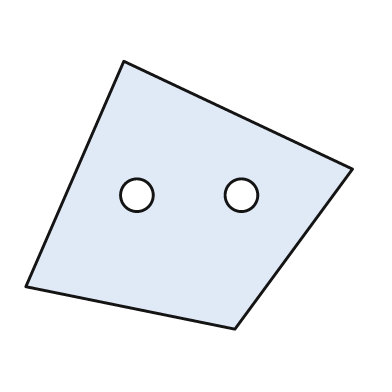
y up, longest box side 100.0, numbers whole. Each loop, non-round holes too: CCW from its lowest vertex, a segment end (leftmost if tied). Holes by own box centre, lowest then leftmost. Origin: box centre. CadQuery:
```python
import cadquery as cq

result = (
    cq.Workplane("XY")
    .moveTo(14.0, -41.0)
    .lineTo(50.0, 8.0)
    .lineTo(-20.0, 41.0)
    .lineTo(-50.0, -28.0)
    .close()
    .moveTo(-16.0, 0.0)
    .circle(5.0)
    .moveTo(16.0, 0.0)
    .circle(5.0)
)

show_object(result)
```